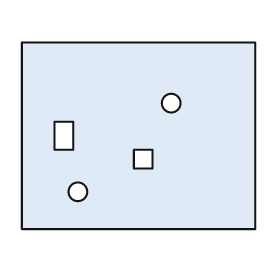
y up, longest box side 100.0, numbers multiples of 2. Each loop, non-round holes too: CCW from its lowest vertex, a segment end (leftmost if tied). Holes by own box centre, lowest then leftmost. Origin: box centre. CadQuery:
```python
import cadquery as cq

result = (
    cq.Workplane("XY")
    .moveTo(-50.0, -40.0)
    .lineTo(50.0, -40.0)
    .lineTo(50.0, 40.0)
    .lineTo(-50.0, 40.0)
    .close()
    .moveTo(-26.0, -24.0)
    .circle(4.0)
    .moveTo(-2.0, -14.0)
    .lineTo(6.0, -14.0)
    .lineTo(6.0, -6.0)
    .lineTo(-2.0, -6.0)
    .close()
    .moveTo(-36.0, -6.0)
    .lineTo(-28.0, -6.0)
    .lineTo(-28.0, 6.0)
    .lineTo(-36.0, 6.0)
    .close()
    .moveTo(14.0, 14.0)
    .circle(4.0)
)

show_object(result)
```